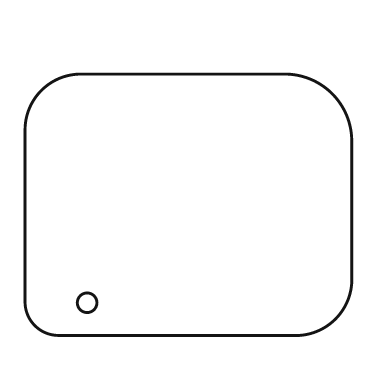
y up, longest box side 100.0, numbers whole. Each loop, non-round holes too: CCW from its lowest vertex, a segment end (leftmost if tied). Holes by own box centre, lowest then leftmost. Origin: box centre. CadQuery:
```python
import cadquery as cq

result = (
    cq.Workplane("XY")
    .moveTo(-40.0, -40.0)
    .lineTo(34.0, -40.0)
    .threePointArc((45.0, -35.0), (50.0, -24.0))
    .lineTo(50.0, 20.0)
    .threePointArc((44.0, 34.0), (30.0, 40.0))
    .lineTo(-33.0, 40.0)
    .threePointArc((-45.0, 35.0), (-50.0, 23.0))
    .lineTo(-50.0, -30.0)
    .threePointArc((-47.0, -37.0), (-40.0, -40.0))
    .close()
    .moveTo(-31.0, -30.0)
    .circle(3.0)
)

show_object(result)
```